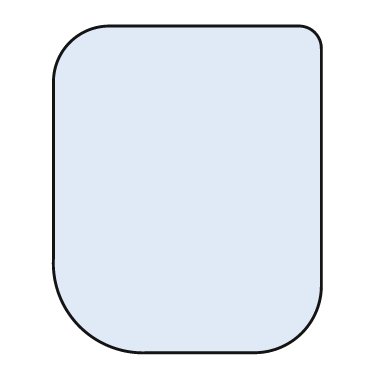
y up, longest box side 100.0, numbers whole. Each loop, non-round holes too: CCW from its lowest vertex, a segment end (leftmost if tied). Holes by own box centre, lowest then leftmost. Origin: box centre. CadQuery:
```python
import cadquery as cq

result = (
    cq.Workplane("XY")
    .moveTo(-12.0, -50.0)
    .lineTo(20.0, -50.0)
    .threePointArc((35.0, -44.0), (41.0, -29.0))
    .lineTo(41.0, 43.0)
    .threePointArc((39.0, 48.0), (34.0, 50.0))
    .lineTo(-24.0, 50.0)
    .threePointArc((-36.0, 45.0), (-41.0, 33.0))
    .lineTo(-41.0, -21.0)
    .threePointArc((-33.0, -42.0), (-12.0, -50.0))
    .close()
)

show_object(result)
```